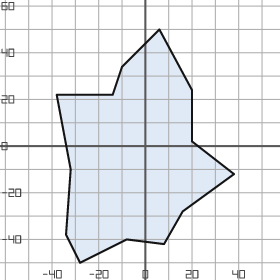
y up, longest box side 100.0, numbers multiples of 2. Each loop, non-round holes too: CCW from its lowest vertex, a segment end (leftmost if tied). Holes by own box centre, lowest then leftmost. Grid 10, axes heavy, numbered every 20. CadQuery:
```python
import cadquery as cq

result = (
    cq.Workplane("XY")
    .moveTo(-28.0, -50.0)
    .lineTo(-8.0, -40.0)
    .lineTo(8.0, -42.0)
    .lineTo(16.0, -28.0)
    .lineTo(38.0, -12.0)
    .lineTo(20.0, 2.0)
    .lineTo(20.0, 24.0)
    .lineTo(6.0, 50.0)
    .lineTo(-10.0, 34.0)
    .lineTo(-14.0, 22.0)
    .lineTo(-38.0, 22.0)
    .lineTo(-32.0, -10.0)
    .lineTo(-34.0, -38.0)
    .close()
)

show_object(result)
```